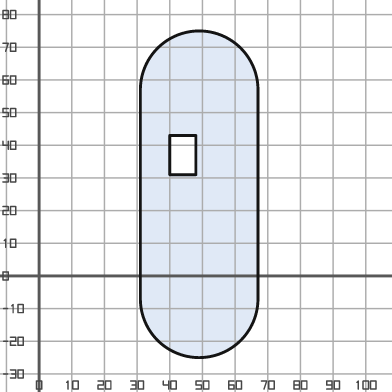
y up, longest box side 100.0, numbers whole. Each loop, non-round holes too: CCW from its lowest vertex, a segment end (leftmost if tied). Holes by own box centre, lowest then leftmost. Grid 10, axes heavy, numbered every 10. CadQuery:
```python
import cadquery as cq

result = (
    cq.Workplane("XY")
    .moveTo(31.0, -7.0)
    .threePointArc((49.0, -25.0), (67.0, -7.0))
    .lineTo(67.0, 57.0)
    .threePointArc((49.0, 75.0), (31.0, 57.0))
    .close()
    .moveTo(40.0, 31.0)
    .lineTo(48.0, 31.0)
    .lineTo(48.0, 43.0)
    .lineTo(40.0, 43.0)
    .close()
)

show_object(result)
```